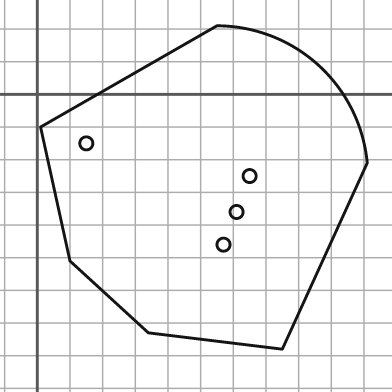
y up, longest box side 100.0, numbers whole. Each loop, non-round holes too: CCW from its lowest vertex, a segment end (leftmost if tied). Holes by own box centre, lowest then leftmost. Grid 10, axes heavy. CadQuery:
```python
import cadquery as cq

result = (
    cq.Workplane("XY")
    .moveTo(75.0, -78.0)
    .lineTo(101.0, -21.0)
    .threePointArc((86.0, 9.0), (55.0, 21.0))
    .lineTo(1.0, -10.0)
    .lineTo(10.0, -51.0)
    .lineTo(34.0, -73.0)
    .close()
    .moveTo(57.0, -46.0)
    .circle(2.0)
    .moveTo(61.0, -36.0)
    .circle(2.0)
    .moveTo(65.0, -25.0)
    .circle(2.0)
    .moveTo(15.0, -15.0)
    .circle(2.0)
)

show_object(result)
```